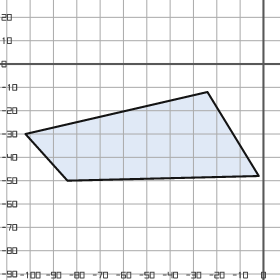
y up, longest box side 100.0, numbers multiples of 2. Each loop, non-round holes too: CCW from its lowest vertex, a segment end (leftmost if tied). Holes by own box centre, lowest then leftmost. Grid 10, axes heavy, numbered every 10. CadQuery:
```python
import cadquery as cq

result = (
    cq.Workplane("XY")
    .moveTo(-84.0, -50.0)
    .lineTo(-2.0, -48.0)
    .lineTo(-24.0, -12.0)
    .lineTo(-102.0, -30.0)
    .close()
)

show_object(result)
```